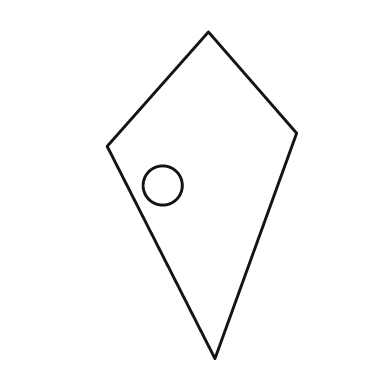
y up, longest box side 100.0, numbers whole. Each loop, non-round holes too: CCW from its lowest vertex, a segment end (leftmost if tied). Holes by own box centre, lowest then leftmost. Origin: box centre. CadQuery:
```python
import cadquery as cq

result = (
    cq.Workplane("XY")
    .moveTo(4.0, -50.0)
    .lineTo(29.0, 19.0)
    .lineTo(2.0, 50.0)
    .lineTo(-29.0, 15.0)
    .close()
    .moveTo(-12.0, 3.0)
    .circle(6.0)
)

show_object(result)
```